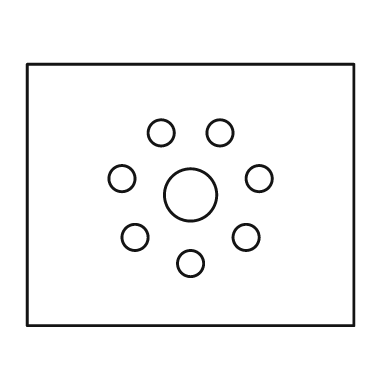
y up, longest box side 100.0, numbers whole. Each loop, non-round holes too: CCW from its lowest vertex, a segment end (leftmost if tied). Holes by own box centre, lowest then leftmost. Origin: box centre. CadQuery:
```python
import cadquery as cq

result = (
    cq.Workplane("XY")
    .moveTo(-50.0, -40.0)
    .lineTo(50.0, -40.0)
    .lineTo(50.0, 40.0)
    .lineTo(-50.0, 40.0)
    .close()
    .moveTo(0.0, -21.0)
    .circle(4.0)
    .moveTo(-17.0, -13.0)
    .circle(4.0)
    .moveTo(17.0, -13.0)
    .circle(4.0)
    .moveTo(0.0, 0.0)
    .circle(8.0)
    .moveTo(-21.0, 5.0)
    .circle(4.0)
    .moveTo(21.0, 5.0)
    .circle(4.0)
    .moveTo(-9.0, 19.0)
    .circle(4.0)
    .moveTo(9.0, 19.0)
    .circle(4.0)
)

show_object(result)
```